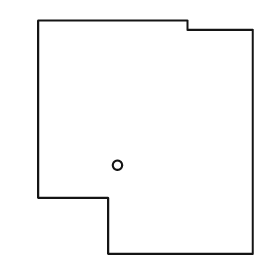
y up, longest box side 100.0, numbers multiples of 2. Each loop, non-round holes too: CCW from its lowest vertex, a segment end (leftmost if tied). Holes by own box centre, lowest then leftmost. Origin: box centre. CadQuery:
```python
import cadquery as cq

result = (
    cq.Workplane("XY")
    .moveTo(-16.0, -50.0)
    .lineTo(46.0, -50.0)
    .lineTo(46.0, 46.0)
    .lineTo(18.0, 46.0)
    .lineTo(18.0, 50.0)
    .lineTo(-46.0, 50.0)
    .lineTo(-46.0, -26.0)
    .lineTo(-16.0, -26.0)
    .close()
    .moveTo(-12.0, -12.0)
    .circle(2.0)
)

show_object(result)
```